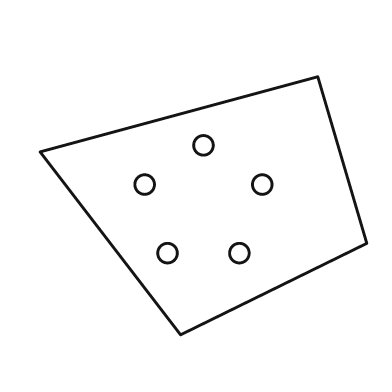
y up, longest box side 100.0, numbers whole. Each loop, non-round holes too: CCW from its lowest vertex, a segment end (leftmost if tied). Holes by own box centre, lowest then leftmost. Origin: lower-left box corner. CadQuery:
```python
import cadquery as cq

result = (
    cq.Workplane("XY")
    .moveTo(43.0, 0.0)
    .lineTo(100.0, 28.0)
    .lineTo(85.0, 79.0)
    .lineTo(0.0, 56.0)
    .close()
    .moveTo(39.0, 25.0)
    .circle(3.0)
    .moveTo(61.0, 25.0)
    .circle(3.0)
    .moveTo(32.0, 46.0)
    .circle(3.0)
    .moveTo(68.0, 46.0)
    .circle(3.0)
    .moveTo(50.0, 58.0)
    .circle(3.0)
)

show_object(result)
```